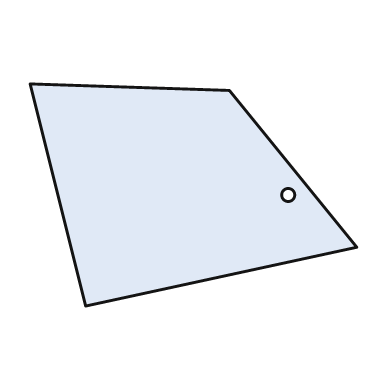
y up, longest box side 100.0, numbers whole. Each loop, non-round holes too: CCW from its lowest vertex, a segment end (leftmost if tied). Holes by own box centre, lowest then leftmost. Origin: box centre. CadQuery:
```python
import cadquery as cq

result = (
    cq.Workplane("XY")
    .moveTo(-33.0, -34.0)
    .lineTo(50.0, -16.0)
    .lineTo(11.0, 32.0)
    .lineTo(-50.0, 34.0)
    .close()
    .moveTo(29.0, 0.0)
    .circle(2.0)
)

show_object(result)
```